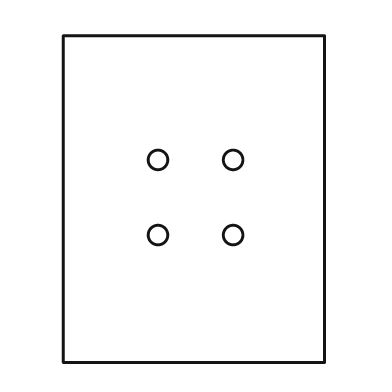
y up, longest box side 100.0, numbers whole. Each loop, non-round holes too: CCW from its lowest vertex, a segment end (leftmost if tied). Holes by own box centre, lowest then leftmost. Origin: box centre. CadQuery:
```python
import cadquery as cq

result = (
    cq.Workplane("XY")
    .moveTo(-40.0, -50.0)
    .lineTo(40.0, -50.0)
    .lineTo(40.0, 50.0)
    .lineTo(-40.0, 50.0)
    .close()
    .moveTo(-11.0, -11.0)
    .circle(3.0)
    .moveTo(12.0, -11.0)
    .circle(3.0)
    .moveTo(-11.0, 12.0)
    .circle(3.0)
    .moveTo(12.0, 12.0)
    .circle(3.0)
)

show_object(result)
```